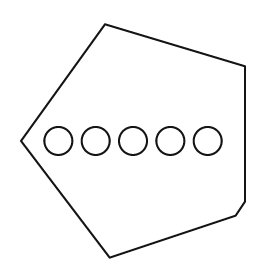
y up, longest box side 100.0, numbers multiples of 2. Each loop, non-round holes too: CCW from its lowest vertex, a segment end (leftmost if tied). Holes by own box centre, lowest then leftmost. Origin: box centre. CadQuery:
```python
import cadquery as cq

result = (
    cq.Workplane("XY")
    .moveTo(-10.0, -50.0)
    .lineTo(44.0, -32.0)
    .lineTo(48.0, -26.0)
    .lineTo(48.0, 32.0)
    .lineTo(-12.0, 50.0)
    .lineTo(-48.0, 0.0)
    .close()
    .moveTo(-32.0, 0.0)
    .circle(6.0)
    .moveTo(-16.0, 0.0)
    .circle(6.0)
    .moveTo(0.0, 0.0)
    .circle(6.0)
    .moveTo(16.0, 0.0)
    .circle(6.0)
    .moveTo(32.0, 0.0)
    .circle(6.0)
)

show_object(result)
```